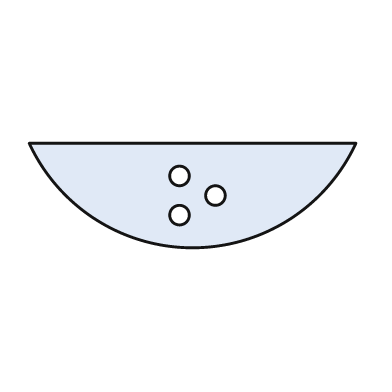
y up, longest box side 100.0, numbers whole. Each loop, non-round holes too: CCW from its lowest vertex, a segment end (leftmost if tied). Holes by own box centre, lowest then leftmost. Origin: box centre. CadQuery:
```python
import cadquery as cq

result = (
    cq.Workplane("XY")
    .moveTo(-50.0, 16.0)
    .threePointArc((0.0, -16.0), (50.0, 16.0))
    .close()
    .moveTo(-4.0, -6.0)
    .circle(3.0)
    .moveTo(7.0, 0.0)
    .circle(3.0)
    .moveTo(-4.0, 6.0)
    .circle(3.0)
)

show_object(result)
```